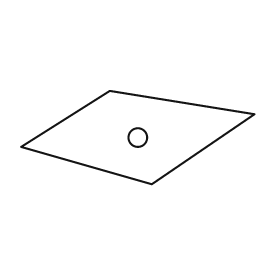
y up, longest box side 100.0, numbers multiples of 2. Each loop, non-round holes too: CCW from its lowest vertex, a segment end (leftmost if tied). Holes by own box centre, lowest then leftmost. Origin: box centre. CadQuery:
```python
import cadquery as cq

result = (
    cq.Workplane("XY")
    .moveTo(6.0, -20.0)
    .lineTo(50.0, 10.0)
    .lineTo(-12.0, 20.0)
    .lineTo(-50.0, -4.0)
    .close()
    .moveTo(0.0, 0.0)
    .circle(4.0)
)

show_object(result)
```